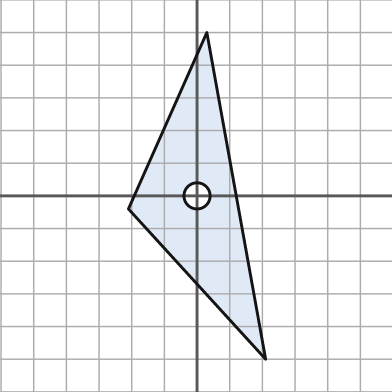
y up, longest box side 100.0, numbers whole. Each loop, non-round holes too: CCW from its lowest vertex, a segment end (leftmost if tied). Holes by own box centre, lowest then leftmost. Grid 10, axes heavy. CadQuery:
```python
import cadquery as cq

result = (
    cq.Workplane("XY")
    .moveTo(21.0, -50.0)
    .lineTo(3.0, 50.0)
    .lineTo(-21.0, -4.0)
    .close()
    .moveTo(0.0, 0.0)
    .circle(4.0)
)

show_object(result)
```